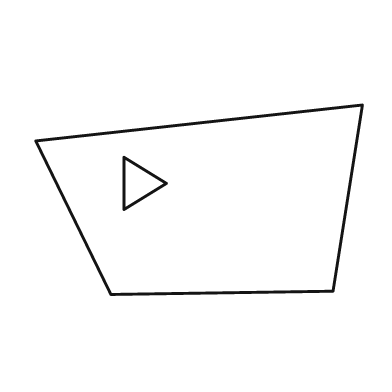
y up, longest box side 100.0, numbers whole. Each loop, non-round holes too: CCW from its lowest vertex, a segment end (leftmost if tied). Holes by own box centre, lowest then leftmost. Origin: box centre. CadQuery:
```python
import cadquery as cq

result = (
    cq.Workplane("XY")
    .moveTo(-27.0, -29.0)
    .lineTo(41.0, -28.0)
    .lineTo(50.0, 29.0)
    .lineTo(-50.0, 18.0)
    .close()
    .moveTo(-23.0, -3.0)
    .lineTo(-10.0, 5.0)
    .lineTo(-23.0, 13.0)
    .close()
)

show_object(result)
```